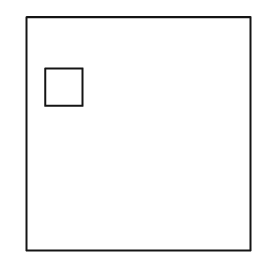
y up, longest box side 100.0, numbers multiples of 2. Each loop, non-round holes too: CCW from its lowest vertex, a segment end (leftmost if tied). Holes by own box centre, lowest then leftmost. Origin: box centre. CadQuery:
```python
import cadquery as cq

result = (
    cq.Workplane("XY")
    .moveTo(-48.0, -50.0)
    .lineTo(48.0, -50.0)
    .lineTo(48.0, 50.0)
    .lineTo(-48.0, 50.0)
    .close()
    .moveTo(-40.0, 12.0)
    .lineTo(-24.0, 12.0)
    .lineTo(-24.0, 28.0)
    .lineTo(-40.0, 28.0)
    .close()
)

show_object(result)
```